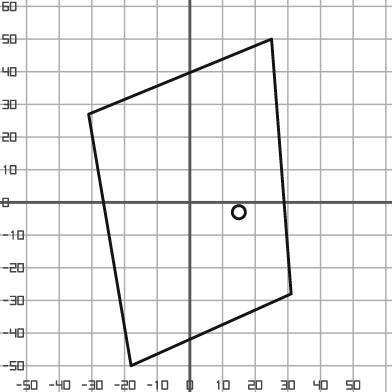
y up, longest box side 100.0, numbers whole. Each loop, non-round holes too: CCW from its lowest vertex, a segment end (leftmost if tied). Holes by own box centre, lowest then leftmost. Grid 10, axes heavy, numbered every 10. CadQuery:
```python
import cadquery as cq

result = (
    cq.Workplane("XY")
    .moveTo(-18.0, -50.0)
    .lineTo(31.0, -28.0)
    .lineTo(25.0, 50.0)
    .lineTo(-31.0, 27.0)
    .close()
    .moveTo(15.0, -3.0)
    .circle(2.0)
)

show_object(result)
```